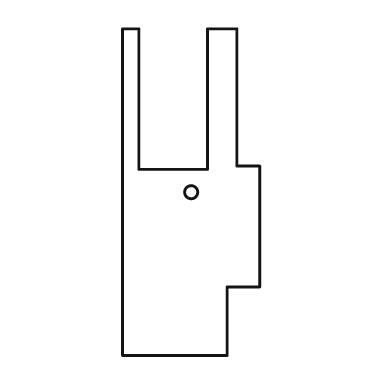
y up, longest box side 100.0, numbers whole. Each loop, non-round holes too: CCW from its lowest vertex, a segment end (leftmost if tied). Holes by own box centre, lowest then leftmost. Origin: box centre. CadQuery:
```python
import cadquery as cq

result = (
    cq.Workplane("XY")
    .moveTo(-21.0, -50.0)
    .lineTo(11.0, -50.0)
    .lineTo(11.0, -29.0)
    .lineTo(21.0, -29.0)
    .lineTo(21.0, 8.0)
    .lineTo(14.0, 8.0)
    .lineTo(14.0, 50.0)
    .lineTo(5.0, 50.0)
    .lineTo(5.0, 7.0)
    .lineTo(-16.0, 7.0)
    .lineTo(-16.0, 50.0)
    .lineTo(-21.0, 50.0)
    .close()
    .moveTo(0.0, 0.0)
    .circle(2.0)
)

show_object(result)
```